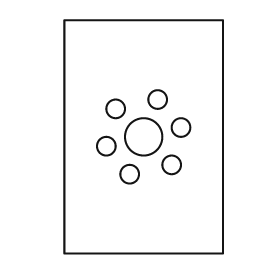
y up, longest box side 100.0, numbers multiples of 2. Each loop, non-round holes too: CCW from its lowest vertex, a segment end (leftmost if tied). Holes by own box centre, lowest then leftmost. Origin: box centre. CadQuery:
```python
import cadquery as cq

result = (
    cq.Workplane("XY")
    .moveTo(-34.0, -50.0)
    .lineTo(34.0, -50.0)
    .lineTo(34.0, 50.0)
    .lineTo(-34.0, 50.0)
    .close()
    .moveTo(-6.0, -16.0)
    .circle(4.0)
    .moveTo(12.0, -12.0)
    .circle(4.0)
    .moveTo(-16.0, -4.0)
    .circle(4.0)
    .moveTo(0.0, 0.0)
    .circle(8.0)
    .moveTo(16.0, 4.0)
    .circle(4.0)
    .moveTo(-12.0, 12.0)
    .circle(4.0)
    .moveTo(6.0, 16.0)
    .circle(4.0)
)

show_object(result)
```